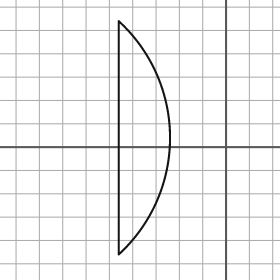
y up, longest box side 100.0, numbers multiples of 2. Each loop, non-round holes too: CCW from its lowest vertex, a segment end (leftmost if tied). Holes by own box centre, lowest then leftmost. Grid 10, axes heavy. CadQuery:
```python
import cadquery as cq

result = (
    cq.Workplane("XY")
    .moveTo(-46.0, -46.0)
    .threePointArc((-24.0, 4.0), (-46.0, 54.0))
    .close()
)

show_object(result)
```